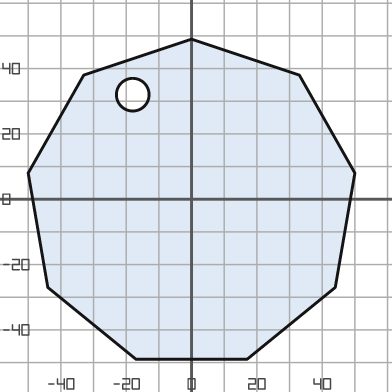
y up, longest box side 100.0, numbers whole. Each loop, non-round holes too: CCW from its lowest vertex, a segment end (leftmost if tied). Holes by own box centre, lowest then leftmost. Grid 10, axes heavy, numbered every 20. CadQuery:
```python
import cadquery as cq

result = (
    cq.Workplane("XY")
    .moveTo(-17.0, -49.0)
    .lineTo(17.0, -49.0)
    .lineTo(44.0, -27.0)
    .lineTo(50.0, 8.0)
    .lineTo(33.0, 38.0)
    .lineTo(0.0, 49.0)
    .lineTo(-33.0, 38.0)
    .lineTo(-50.0, 8.0)
    .lineTo(-44.0, -27.0)
    .close()
    .moveTo(-18.0, 32.0)
    .circle(5.0)
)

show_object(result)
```